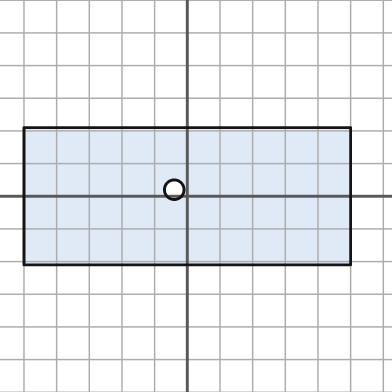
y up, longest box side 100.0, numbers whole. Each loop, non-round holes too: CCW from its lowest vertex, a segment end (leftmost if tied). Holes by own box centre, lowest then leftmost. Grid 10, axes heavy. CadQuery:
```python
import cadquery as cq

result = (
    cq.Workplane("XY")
    .moveTo(-50.0, -21.0)
    .lineTo(50.0, -21.0)
    .lineTo(50.0, 21.0)
    .lineTo(-50.0, 21.0)
    .close()
    .moveTo(-4.0, 2.0)
    .circle(3.0)
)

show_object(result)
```